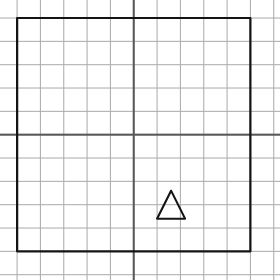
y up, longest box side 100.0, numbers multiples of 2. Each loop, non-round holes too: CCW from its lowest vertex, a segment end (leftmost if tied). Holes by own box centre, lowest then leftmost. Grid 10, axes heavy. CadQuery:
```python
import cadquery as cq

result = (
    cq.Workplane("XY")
    .moveTo(-50.0, -50.0)
    .lineTo(50.0, -50.0)
    .lineTo(50.0, 50.0)
    .lineTo(-50.0, 50.0)
    .close()
    .moveTo(10.0, -36.0)
    .lineTo(22.0, -36.0)
    .lineTo(16.0, -24.0)
    .close()
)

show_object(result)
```